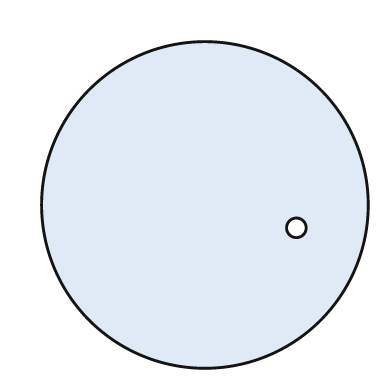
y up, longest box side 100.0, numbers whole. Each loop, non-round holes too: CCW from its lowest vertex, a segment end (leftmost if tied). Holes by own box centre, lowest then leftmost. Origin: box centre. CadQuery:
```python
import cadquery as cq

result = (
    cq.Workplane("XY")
    .moveTo(0.0, 0.0)
    .circle(50.0)
    .moveTo(28.0, -7.0)
    .circle(3.0)
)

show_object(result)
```